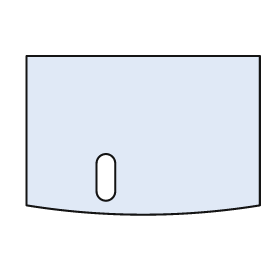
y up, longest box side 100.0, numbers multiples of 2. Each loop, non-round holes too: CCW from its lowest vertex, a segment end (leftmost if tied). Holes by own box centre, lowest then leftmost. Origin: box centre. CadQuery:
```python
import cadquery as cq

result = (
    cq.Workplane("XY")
    .moveTo(-50.0, -30.0)
    .threePointArc((0.0, -34.0), (50.0, -30.0))
    .lineTo(50.0, 34.0)
    .lineTo(-50.0, 34.0)
    .close()
    .moveTo(-20.0, -24.0)
    .threePointArc((-16.0, -28.0), (-12.0, -24.0))
    .lineTo(-12.0, -12.0)
    .threePointArc((-16.0, -8.0), (-20.0, -12.0))
    .close()
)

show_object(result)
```